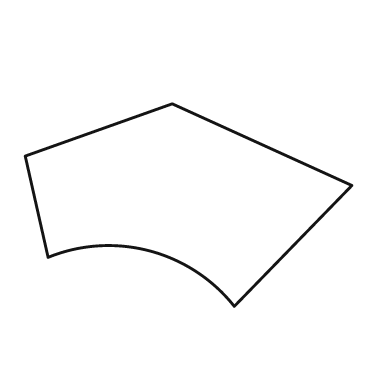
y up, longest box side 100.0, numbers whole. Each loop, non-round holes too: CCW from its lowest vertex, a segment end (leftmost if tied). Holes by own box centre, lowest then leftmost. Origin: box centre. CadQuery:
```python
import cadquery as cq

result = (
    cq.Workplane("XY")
    .moveTo(14.0, -31.0)
    .lineTo(50.0, 6.0)
    .lineTo(-5.0, 31.0)
    .lineTo(-50.0, 15.0)
    .lineTo(-43.0, -16.0)
    .threePointArc((-12.0, -14.0), (14.0, -31.0))
    .close()
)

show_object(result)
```